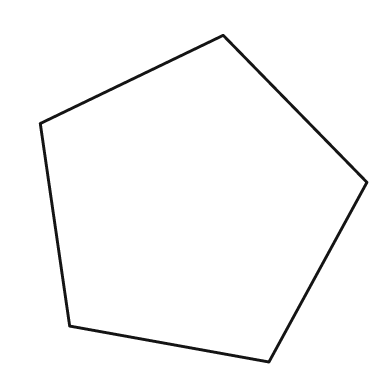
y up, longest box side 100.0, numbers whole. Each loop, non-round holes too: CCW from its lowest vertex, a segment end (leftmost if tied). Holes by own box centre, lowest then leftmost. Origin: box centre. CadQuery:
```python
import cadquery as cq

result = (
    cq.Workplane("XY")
    .moveTo(20.0, -50.0)
    .lineTo(50.0, 5.0)
    .lineTo(6.0, 50.0)
    .lineTo(-50.0, 23.0)
    .lineTo(-41.0, -39.0)
    .close()
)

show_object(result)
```